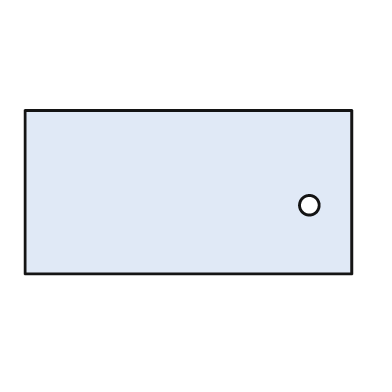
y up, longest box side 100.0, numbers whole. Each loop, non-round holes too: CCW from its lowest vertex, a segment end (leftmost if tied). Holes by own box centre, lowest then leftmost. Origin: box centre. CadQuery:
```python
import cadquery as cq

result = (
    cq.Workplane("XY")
    .moveTo(-50.0, -25.0)
    .lineTo(50.0, -25.0)
    .lineTo(50.0, 25.0)
    .lineTo(-50.0, 25.0)
    .close()
    .moveTo(37.0, -4.0)
    .circle(3.0)
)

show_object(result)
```